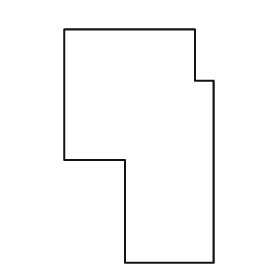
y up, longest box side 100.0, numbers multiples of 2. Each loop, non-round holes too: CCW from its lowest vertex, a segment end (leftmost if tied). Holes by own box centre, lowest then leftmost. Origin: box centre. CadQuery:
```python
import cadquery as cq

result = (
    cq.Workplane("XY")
    .moveTo(-6.0, -50.0)
    .lineTo(32.0, -50.0)
    .lineTo(32.0, 28.0)
    .lineTo(24.0, 28.0)
    .lineTo(24.0, 50.0)
    .lineTo(-32.0, 50.0)
    .lineTo(-32.0, -6.0)
    .lineTo(-6.0, -6.0)
    .close()
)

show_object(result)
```